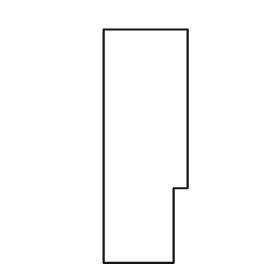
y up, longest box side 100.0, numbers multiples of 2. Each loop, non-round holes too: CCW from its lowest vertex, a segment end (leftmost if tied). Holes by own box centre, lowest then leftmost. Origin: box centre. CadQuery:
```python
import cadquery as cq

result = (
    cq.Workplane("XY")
    .moveTo(-18.0, -50.0)
    .lineTo(12.0, -50.0)
    .lineTo(12.0, -18.0)
    .lineTo(18.0, -18.0)
    .lineTo(18.0, 50.0)
    .lineTo(-18.0, 50.0)
    .close()
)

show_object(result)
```